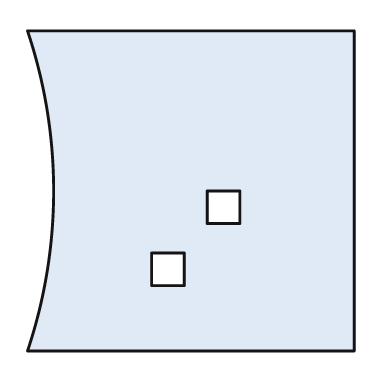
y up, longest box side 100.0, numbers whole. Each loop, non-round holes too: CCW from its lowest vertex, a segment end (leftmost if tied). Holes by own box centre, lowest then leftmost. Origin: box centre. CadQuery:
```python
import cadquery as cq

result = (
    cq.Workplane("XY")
    .moveTo(-50.0, -49.0)
    .lineTo(50.0, -49.0)
    .lineTo(50.0, 49.0)
    .lineTo(-50.0, 49.0)
    .threePointArc((-42.0, 0.0), (-50.0, -49.0))
    .close()
    .moveTo(-12.0, -29.0)
    .lineTo(-2.0, -29.0)
    .lineTo(-2.0, -19.0)
    .lineTo(-12.0, -19.0)
    .close()
    .moveTo(5.0, -10.0)
    .lineTo(15.0, -10.0)
    .lineTo(15.0, 0.0)
    .lineTo(5.0, 0.0)
    .close()
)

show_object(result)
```